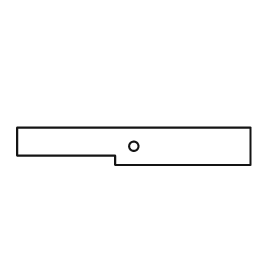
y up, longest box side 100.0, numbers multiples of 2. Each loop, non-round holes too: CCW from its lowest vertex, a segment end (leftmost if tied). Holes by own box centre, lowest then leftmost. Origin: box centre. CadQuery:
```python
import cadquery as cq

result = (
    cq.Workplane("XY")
    .moveTo(-8.0, -8.0)
    .lineTo(50.0, -8.0)
    .lineTo(50.0, 8.0)
    .lineTo(-50.0, 8.0)
    .lineTo(-50.0, -4.0)
    .lineTo(-8.0, -4.0)
    .close()
    .moveTo(0.0, 0.0)
    .circle(2.0)
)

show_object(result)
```